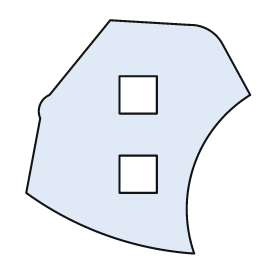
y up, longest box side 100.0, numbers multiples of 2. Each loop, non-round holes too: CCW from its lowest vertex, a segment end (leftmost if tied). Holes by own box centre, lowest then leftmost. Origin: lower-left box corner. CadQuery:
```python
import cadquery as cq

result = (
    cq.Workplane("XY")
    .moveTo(72.0, 0.0)
    .threePointArc((72.0, 38.0), (96.0, 68.0))
    .lineTo(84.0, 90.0)
    .threePointArc((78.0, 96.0), (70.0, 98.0))
    .lineTo(36.0, 100.0)
    .lineTo(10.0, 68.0)
    .threePointArc((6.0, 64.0), (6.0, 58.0))
    .lineTo(0.0, 26.0)
    .threePointArc((34.0, 8.0), (72.0, 0.0))
    .close()
    .moveTo(40.0, 26.0)
    .lineTo(56.0, 26.0)
    .lineTo(56.0, 42.0)
    .lineTo(40.0, 42.0)
    .close()
    .moveTo(40.0, 60.0)
    .lineTo(56.0, 60.0)
    .lineTo(56.0, 76.0)
    .lineTo(40.0, 76.0)
    .close()
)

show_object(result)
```